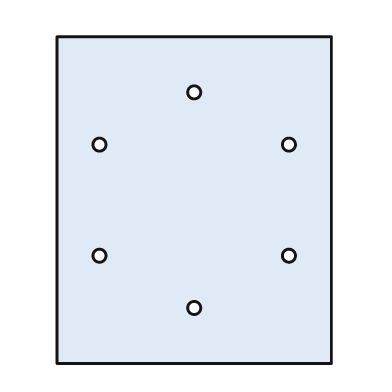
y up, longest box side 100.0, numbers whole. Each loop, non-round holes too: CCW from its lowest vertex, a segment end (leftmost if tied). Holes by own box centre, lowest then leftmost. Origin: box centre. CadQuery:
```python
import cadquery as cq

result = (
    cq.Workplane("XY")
    .moveTo(-42.0, -50.0)
    .lineTo(42.0, -50.0)
    .lineTo(42.0, 50.0)
    .lineTo(-42.0, 50.0)
    .close()
    .moveTo(0.0, -33.0)
    .circle(2.0)
    .moveTo(-29.0, -17.0)
    .circle(2.0)
    .moveTo(29.0, -17.0)
    .circle(2.0)
    .moveTo(-29.0, 17.0)
    .circle(2.0)
    .moveTo(29.0, 17.0)
    .circle(2.0)
    .moveTo(0.0, 33.0)
    .circle(2.0)
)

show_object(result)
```